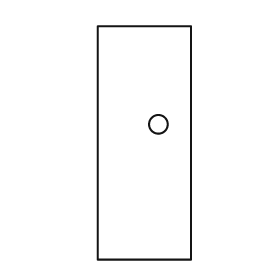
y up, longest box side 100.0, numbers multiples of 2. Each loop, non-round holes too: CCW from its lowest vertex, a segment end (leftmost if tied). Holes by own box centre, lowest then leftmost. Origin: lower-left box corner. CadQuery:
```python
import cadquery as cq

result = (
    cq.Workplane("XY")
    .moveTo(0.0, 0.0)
    .lineTo(40.0, 0.0)
    .lineTo(40.0, 100.0)
    .lineTo(0.0, 100.0)
    .close()
    .moveTo(26.0, 58.0)
    .circle(4.0)
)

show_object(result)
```